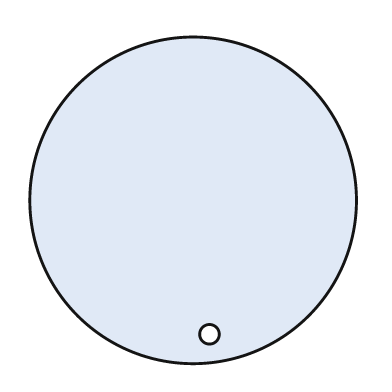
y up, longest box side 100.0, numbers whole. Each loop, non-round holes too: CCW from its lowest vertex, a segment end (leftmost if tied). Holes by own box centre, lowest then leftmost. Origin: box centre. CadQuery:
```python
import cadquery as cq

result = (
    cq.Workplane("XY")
    .moveTo(0.0, 0.0)
    .circle(50.0)
    .moveTo(5.0, -41.0)
    .circle(3.0)
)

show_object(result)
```